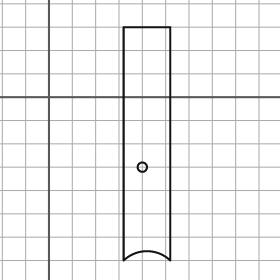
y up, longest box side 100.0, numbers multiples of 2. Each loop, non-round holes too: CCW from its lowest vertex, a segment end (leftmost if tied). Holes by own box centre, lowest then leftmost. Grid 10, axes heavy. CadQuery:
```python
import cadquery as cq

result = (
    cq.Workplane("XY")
    .moveTo(32.0, -70.0)
    .threePointArc((42.0, -66.0), (52.0, -70.0))
    .lineTo(52.0, 30.0)
    .lineTo(32.0, 30.0)
    .close()
    .moveTo(40.0, -30.0)
    .circle(2.0)
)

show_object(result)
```